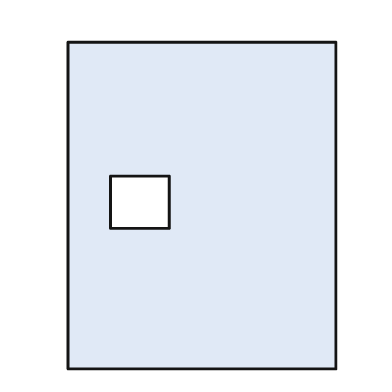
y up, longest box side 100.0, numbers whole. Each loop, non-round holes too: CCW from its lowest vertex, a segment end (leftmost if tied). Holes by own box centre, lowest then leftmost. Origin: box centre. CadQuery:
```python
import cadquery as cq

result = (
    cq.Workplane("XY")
    .moveTo(-41.0, -50.0)
    .lineTo(41.0, -50.0)
    .lineTo(41.0, 50.0)
    .lineTo(-41.0, 50.0)
    .close()
    .moveTo(-28.0, -7.0)
    .lineTo(-10.0, -7.0)
    .lineTo(-10.0, 9.0)
    .lineTo(-28.0, 9.0)
    .close()
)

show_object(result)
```